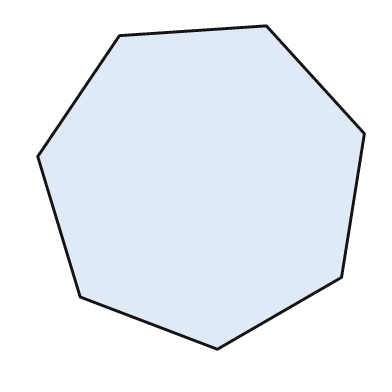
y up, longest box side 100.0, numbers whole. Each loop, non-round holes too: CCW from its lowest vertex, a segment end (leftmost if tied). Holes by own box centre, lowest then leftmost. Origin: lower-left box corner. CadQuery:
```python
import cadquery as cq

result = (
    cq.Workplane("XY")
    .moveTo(55.0, 0.0)
    .lineTo(93.0, 22.0)
    .lineTo(100.0, 66.0)
    .lineTo(70.0, 99.0)
    .lineTo(25.0, 96.0)
    .lineTo(0.0, 59.0)
    .lineTo(13.0, 16.0)
    .close()
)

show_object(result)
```